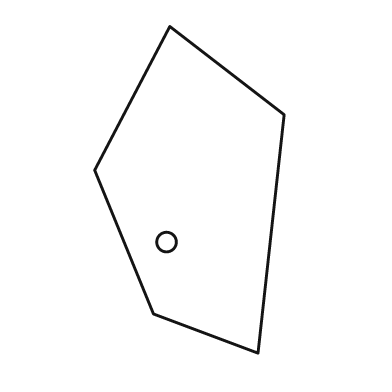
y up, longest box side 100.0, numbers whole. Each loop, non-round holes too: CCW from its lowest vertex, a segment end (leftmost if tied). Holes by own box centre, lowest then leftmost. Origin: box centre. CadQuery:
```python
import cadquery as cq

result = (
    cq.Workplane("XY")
    .moveTo(21.0, -50.0)
    .lineTo(29.0, 23.0)
    .lineTo(-6.0, 50.0)
    .lineTo(-29.0, 6.0)
    .lineTo(-11.0, -38.0)
    .close()
    .moveTo(-7.0, -16.0)
    .circle(3.0)
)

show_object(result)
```